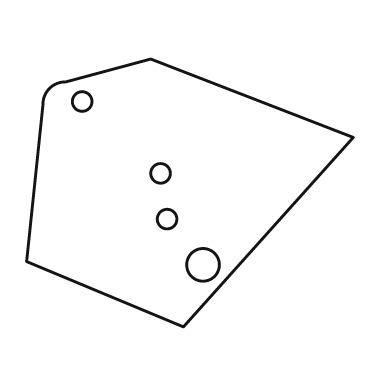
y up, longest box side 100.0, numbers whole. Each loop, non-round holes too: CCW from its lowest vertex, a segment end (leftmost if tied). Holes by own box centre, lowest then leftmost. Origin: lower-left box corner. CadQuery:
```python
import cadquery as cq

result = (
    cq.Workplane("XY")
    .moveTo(48.0, 0.0)
    .lineTo(100.0, 58.0)
    .lineTo(38.0, 82.0)
    .lineTo(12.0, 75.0)
    .threePointArc((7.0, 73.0), (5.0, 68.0))
    .lineTo(0.0, 20.0)
    .close()
    .moveTo(54.0, 19.0)
    .circle(5.0)
    .moveTo(43.0, 33.0)
    .circle(3.0)
    .moveTo(41.0, 47.0)
    .circle(3.0)
    .moveTo(17.0, 69.0)
    .circle(3.0)
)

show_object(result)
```